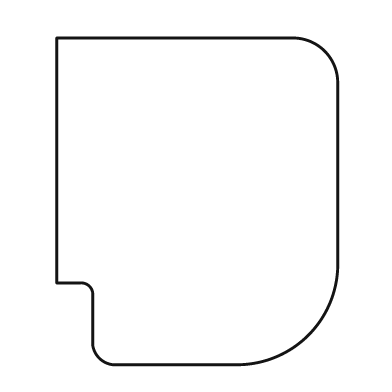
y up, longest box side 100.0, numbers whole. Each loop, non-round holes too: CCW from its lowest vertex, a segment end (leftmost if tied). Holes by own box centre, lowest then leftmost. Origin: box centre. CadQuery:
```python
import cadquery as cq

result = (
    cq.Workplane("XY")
    .moveTo(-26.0, -50.0)
    .lineTo(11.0, -50.0)
    .threePointArc((34.0, -41.0), (43.0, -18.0))
    .lineTo(43.0, 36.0)
    .threePointArc((39.0, 46.0), (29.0, 50.0))
    .lineTo(-43.0, 50.0)
    .lineTo(-43.0, -25.0)
    .lineTo(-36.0, -25.0)
    .threePointArc((-33.0, -26.0), (-32.0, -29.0))
    .lineTo(-32.0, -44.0)
    .threePointArc((-30.0, -48.0), (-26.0, -50.0))
    .close()
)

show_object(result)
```